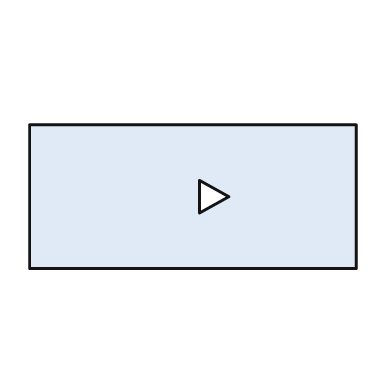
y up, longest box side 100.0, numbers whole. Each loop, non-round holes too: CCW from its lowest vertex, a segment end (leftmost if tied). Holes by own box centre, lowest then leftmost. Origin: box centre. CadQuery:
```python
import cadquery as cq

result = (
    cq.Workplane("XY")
    .moveTo(-50.0, -22.0)
    .lineTo(50.0, -22.0)
    .lineTo(50.0, 22.0)
    .lineTo(-50.0, 22.0)
    .close()
    .moveTo(2.0, -5.0)
    .lineTo(11.0, 0.0)
    .lineTo(2.0, 5.0)
    .close()
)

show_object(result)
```